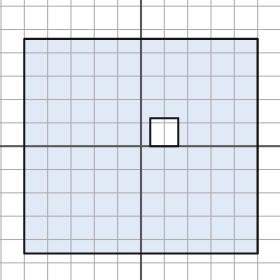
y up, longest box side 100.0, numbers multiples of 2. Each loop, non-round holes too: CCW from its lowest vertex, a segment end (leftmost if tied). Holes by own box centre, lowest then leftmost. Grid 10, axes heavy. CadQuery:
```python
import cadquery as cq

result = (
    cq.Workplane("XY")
    .moveTo(-50.0, -46.0)
    .lineTo(50.0, -46.0)
    .lineTo(50.0, 46.0)
    .lineTo(-50.0, 46.0)
    .close()
    .moveTo(4.0, 0.0)
    .lineTo(16.0, 0.0)
    .lineTo(16.0, 12.0)
    .lineTo(4.0, 12.0)
    .close()
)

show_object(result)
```